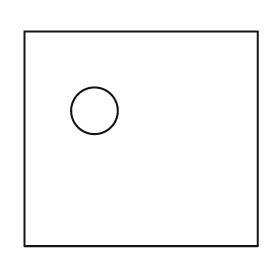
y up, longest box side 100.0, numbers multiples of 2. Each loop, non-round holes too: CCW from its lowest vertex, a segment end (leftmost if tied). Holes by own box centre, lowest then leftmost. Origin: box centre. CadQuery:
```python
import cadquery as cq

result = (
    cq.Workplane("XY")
    .moveTo(-50.0, -46.0)
    .lineTo(50.0, -46.0)
    .lineTo(50.0, 46.0)
    .lineTo(-50.0, 46.0)
    .close()
    .moveTo(-20.0, 12.0)
    .circle(10.0)
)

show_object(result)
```